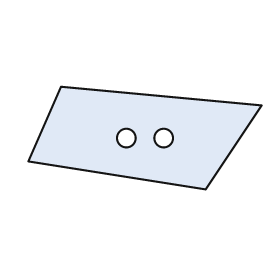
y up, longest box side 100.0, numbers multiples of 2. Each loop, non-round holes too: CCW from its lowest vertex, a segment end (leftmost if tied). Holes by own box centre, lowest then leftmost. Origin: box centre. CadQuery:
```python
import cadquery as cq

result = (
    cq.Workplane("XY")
    .moveTo(26.0, -22.0)
    .lineTo(50.0, 14.0)
    .lineTo(-36.0, 22.0)
    .lineTo(-50.0, -10.0)
    .close()
    .moveTo(-8.0, 0.0)
    .circle(4.0)
    .moveTo(8.0, 0.0)
    .circle(4.0)
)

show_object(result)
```